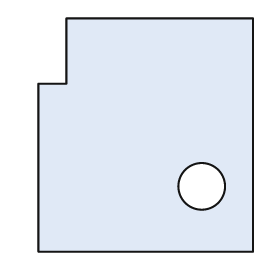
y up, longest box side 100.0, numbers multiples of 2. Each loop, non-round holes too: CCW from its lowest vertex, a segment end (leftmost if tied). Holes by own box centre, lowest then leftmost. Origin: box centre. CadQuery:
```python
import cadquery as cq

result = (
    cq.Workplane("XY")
    .moveTo(-46.0, -50.0)
    .lineTo(46.0, -50.0)
    .lineTo(46.0, 50.0)
    .lineTo(-34.0, 50.0)
    .lineTo(-34.0, 22.0)
    .lineTo(-46.0, 22.0)
    .close()
    .moveTo(24.0, -22.0)
    .circle(10.0)
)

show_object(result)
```